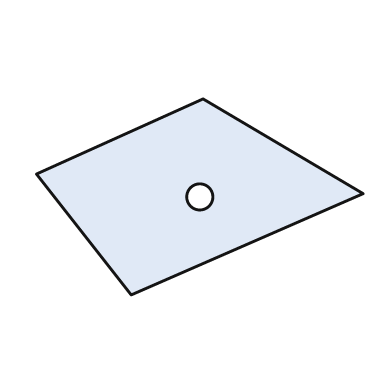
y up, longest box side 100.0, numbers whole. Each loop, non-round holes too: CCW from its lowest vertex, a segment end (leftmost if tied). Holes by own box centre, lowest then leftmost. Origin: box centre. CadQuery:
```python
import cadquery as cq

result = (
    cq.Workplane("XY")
    .moveTo(-21.0, -30.0)
    .lineTo(50.0, 1.0)
    .lineTo(1.0, 30.0)
    .lineTo(-50.0, 7.0)
    .close()
    .moveTo(0.0, 0.0)
    .circle(4.0)
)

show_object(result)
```